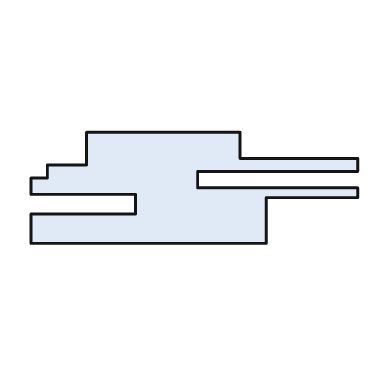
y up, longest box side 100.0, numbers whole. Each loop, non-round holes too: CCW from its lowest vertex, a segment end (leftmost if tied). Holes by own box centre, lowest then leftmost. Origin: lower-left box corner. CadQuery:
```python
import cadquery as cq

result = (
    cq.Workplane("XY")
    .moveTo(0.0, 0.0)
    .lineTo(72.0, 0.0)
    .lineTo(72.0, 14.0)
    .lineTo(100.0, 14.0)
    .lineTo(100.0, 17.0)
    .lineTo(51.0, 17.0)
    .lineTo(51.0, 22.0)
    .lineTo(100.0, 22.0)
    .lineTo(100.0, 26.0)
    .lineTo(64.0, 26.0)
    .lineTo(64.0, 34.0)
    .lineTo(17.0, 34.0)
    .lineTo(17.0, 24.0)
    .lineTo(5.0, 24.0)
    .lineTo(5.0, 20.0)
    .lineTo(0.0, 20.0)
    .lineTo(0.0, 15.0)
    .lineTo(32.0, 15.0)
    .lineTo(32.0, 9.0)
    .lineTo(0.0, 9.0)
    .close()
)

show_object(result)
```